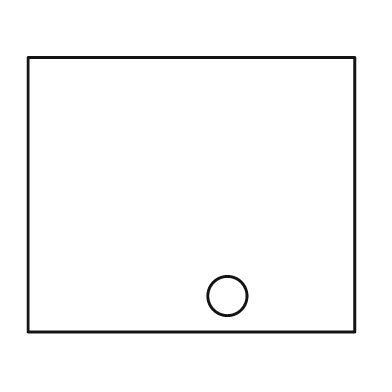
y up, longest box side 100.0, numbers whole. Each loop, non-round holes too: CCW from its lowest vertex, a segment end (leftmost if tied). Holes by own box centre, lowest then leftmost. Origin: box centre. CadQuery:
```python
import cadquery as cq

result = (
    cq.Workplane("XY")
    .moveTo(-50.0, -42.0)
    .lineTo(50.0, -42.0)
    .lineTo(50.0, 42.0)
    .lineTo(-50.0, 42.0)
    .close()
    .moveTo(11.0, -31.0)
    .circle(6.0)
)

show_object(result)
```